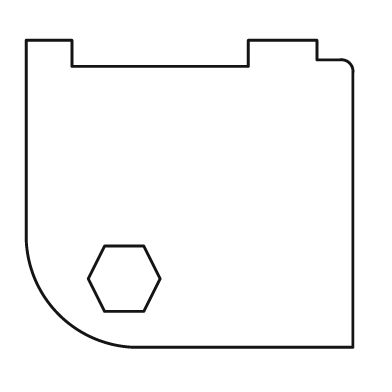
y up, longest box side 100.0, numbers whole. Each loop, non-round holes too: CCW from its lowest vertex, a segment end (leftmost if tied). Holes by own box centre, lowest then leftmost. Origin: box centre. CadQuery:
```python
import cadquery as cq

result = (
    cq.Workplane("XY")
    .moveTo(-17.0, -47.0)
    .lineTo(50.0, -47.0)
    .lineTo(50.0, 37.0)
    .threePointArc((49.0, 40.0), (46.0, 41.0))
    .lineTo(39.0, 41.0)
    .lineTo(39.0, 47.0)
    .lineTo(18.0, 47.0)
    .lineTo(18.0, 39.0)
    .lineTo(-36.0, 39.0)
    .lineTo(-36.0, 47.0)
    .lineTo(-50.0, 47.0)
    .lineTo(-50.0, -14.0)
    .threePointArc((-40.0, -37.0), (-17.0, -47.0))
    .close()
    .moveTo(-26.0, -36.0)
    .lineTo(-14.0, -36.0)
    .lineTo(-9.0, -26.0)
    .lineTo(-14.0, -16.0)
    .lineTo(-26.0, -16.0)
    .lineTo(-31.0, -26.0)
    .close()
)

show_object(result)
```